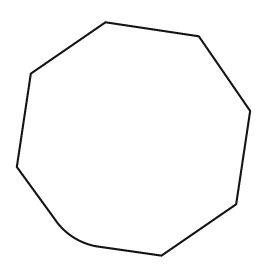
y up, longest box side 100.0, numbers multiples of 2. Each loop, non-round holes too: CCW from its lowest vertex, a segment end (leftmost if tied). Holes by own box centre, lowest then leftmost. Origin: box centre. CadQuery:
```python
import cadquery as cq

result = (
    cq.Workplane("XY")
    .moveTo(12.0, -50.0)
    .lineTo(44.0, -28.0)
    .lineTo(50.0, 12.0)
    .lineTo(28.0, 44.0)
    .lineTo(-12.0, 50.0)
    .lineTo(-44.0, 28.0)
    .lineTo(-50.0, -12.0)
    .lineTo(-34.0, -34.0)
    .threePointArc((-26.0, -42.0), (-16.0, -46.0))
    .close()
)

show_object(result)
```